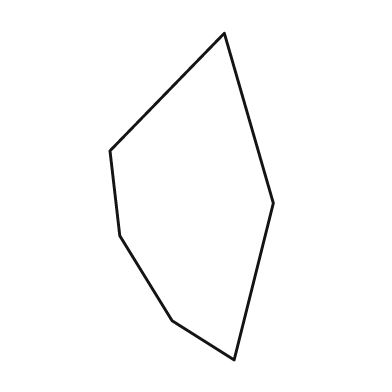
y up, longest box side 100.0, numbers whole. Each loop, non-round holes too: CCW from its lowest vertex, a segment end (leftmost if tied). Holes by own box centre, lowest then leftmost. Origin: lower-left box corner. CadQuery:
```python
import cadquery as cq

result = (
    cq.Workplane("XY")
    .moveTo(38.0, 0.0)
    .lineTo(50.0, 48.0)
    .lineTo(35.0, 100.0)
    .lineTo(0.0, 64.0)
    .lineTo(3.0, 38.0)
    .lineTo(19.0, 12.0)
    .close()
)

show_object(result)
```